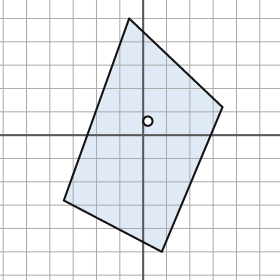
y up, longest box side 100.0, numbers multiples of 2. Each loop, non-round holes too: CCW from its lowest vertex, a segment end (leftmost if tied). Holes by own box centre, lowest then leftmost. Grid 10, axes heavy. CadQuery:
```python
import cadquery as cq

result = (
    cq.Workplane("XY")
    .moveTo(8.0, -50.0)
    .lineTo(34.0, 12.0)
    .lineTo(-6.0, 50.0)
    .lineTo(-34.0, -28.0)
    .close()
    .moveTo(2.0, 6.0)
    .circle(2.0)
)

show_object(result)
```